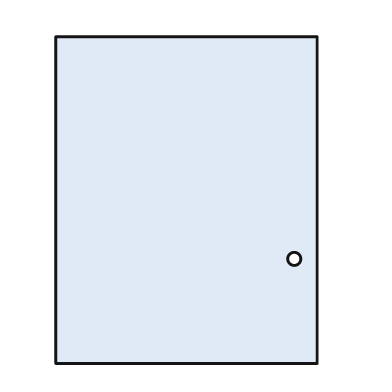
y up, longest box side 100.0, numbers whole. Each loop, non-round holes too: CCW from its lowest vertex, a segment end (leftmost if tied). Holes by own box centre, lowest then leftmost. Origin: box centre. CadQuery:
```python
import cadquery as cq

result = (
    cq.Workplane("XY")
    .moveTo(-40.0, -50.0)
    .lineTo(40.0, -50.0)
    .lineTo(40.0, 50.0)
    .lineTo(-40.0, 50.0)
    .close()
    .moveTo(33.0, -18.0)
    .circle(2.0)
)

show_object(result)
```